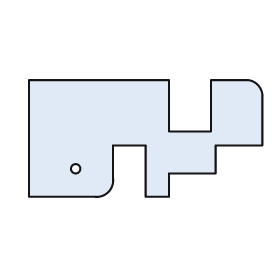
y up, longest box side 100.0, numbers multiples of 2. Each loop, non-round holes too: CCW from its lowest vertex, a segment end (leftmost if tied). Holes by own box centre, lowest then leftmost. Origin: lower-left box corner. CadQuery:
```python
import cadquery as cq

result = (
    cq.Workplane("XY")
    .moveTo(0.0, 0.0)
    .lineTo(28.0, 0.0)
    .threePointArc((34.0, 2.0), (36.0, 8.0))
    .lineTo(36.0, 22.0)
    .lineTo(50.0, 22.0)
    .lineTo(50.0, 0.0)
    .lineTo(60.0, 0.0)
    .lineTo(60.0, 10.0)
    .lineTo(80.0, 10.0)
    .lineTo(80.0, 22.0)
    .lineTo(100.0, 22.0)
    .lineTo(100.0, 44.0)
    .threePointArc((98.0, 48.0), (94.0, 50.0))
    .lineTo(78.0, 50.0)
    .lineTo(78.0, 28.0)
    .lineTo(60.0, 28.0)
    .lineTo(60.0, 50.0)
    .lineTo(0.0, 50.0)
    .close()
    .moveTo(20.0, 12.0)
    .circle(2.0)
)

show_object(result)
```